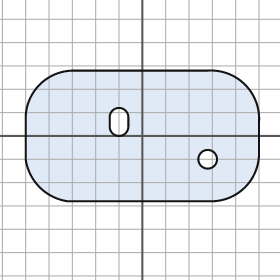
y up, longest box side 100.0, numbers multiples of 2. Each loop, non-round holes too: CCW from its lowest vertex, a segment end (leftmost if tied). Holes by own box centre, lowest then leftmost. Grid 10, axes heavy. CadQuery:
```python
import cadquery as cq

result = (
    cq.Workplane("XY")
    .moveTo(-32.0, -28.0)
    .lineTo(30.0, -28.0)
    .threePointArc((44.0, -22.0), (50.0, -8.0))
    .lineTo(50.0, 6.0)
    .threePointArc((44.0, 22.0), (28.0, 28.0))
    .lineTo(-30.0, 28.0)
    .threePointArc((-44.0, 22.0), (-50.0, 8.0))
    .lineTo(-50.0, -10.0)
    .threePointArc((-44.0, -22.0), (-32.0, -28.0))
    .close()
    .moveTo(28.0, -10.0)
    .circle(4.0)
    .moveTo(-14.0, 4.0)
    .threePointArc((-10.0, 0.0), (-6.0, 4.0))
    .lineTo(-6.0, 8.0)
    .threePointArc((-10.0, 12.0), (-14.0, 8.0))
    .close()
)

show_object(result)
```